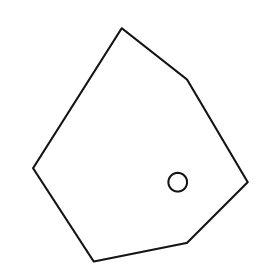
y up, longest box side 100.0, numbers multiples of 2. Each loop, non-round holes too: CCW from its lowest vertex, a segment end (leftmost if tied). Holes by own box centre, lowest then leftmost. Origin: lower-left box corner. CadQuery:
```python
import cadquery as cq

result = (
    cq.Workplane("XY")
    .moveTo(26.0, 0.0)
    .lineTo(66.0, 8.0)
    .lineTo(92.0, 34.0)
    .lineTo(66.0, 78.0)
    .lineTo(38.0, 100.0)
    .lineTo(0.0, 40.0)
    .close()
    .moveTo(62.0, 34.0)
    .circle(4.0)
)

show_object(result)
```